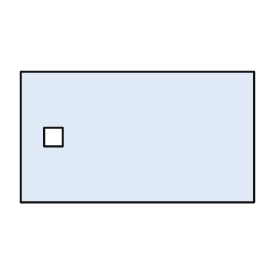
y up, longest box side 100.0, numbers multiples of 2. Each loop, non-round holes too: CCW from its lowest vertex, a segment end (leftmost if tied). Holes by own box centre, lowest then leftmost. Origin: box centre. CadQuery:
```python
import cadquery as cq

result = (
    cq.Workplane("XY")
    .moveTo(-50.0, -28.0)
    .lineTo(50.0, -28.0)
    .lineTo(50.0, 28.0)
    .lineTo(-50.0, 28.0)
    .close()
    .moveTo(-40.0, -4.0)
    .lineTo(-32.0, -4.0)
    .lineTo(-32.0, 4.0)
    .lineTo(-40.0, 4.0)
    .close()
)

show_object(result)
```